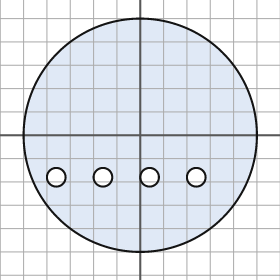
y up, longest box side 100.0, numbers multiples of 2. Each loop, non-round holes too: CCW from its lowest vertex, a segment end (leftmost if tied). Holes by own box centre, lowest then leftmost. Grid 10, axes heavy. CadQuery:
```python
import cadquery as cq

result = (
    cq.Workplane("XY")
    .moveTo(0.0, 0.0)
    .circle(50.0)
    .moveTo(-36.0, -18.0)
    .circle(4.0)
    .moveTo(-16.0, -18.0)
    .circle(4.0)
    .moveTo(4.0, -18.0)
    .circle(4.0)
    .moveTo(24.0, -18.0)
    .circle(4.0)
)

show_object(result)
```